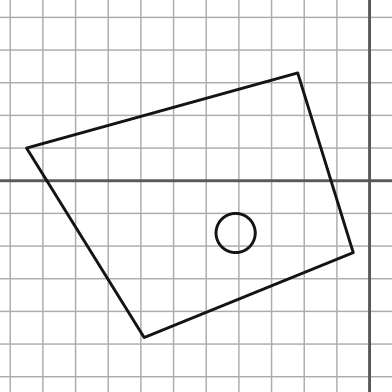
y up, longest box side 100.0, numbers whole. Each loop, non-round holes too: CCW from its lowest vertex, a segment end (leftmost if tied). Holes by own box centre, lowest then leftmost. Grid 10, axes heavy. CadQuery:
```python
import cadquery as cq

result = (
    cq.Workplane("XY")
    .moveTo(-69.0, -48.0)
    .lineTo(-5.0, -22.0)
    .lineTo(-22.0, 33.0)
    .lineTo(-105.0, 10.0)
    .close()
    .moveTo(-41.0, -16.0)
    .circle(6.0)
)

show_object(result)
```